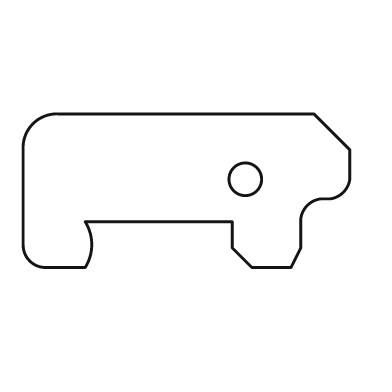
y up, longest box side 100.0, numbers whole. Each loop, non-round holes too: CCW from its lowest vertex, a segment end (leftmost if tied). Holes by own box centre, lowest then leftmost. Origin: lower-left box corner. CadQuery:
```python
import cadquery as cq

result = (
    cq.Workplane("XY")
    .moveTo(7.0, 0.0)
    .lineTo(19.0, 0.0)
    .threePointArc((21.0, 7.0), (19.0, 14.0))
    .lineTo(64.0, 14.0)
    .lineTo(64.0, 6.0)
    .lineTo(70.0, 0.0)
    .lineTo(82.0, 0.0)
    .lineTo(85.0, 6.0)
    .lineTo(85.0, 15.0)
    .threePointArc((87.0, 19.0), (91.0, 21.0))
    .lineTo(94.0, 21.0)
    .threePointArc((98.0, 23.0), (100.0, 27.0))
    .lineTo(100.0, 36.0)
    .lineTo(89.0, 47.0)
    .lineTo(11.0, 47.0)
    .threePointArc((3.0, 44.0), (0.0, 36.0))
    .lineTo(0.0, 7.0)
    .threePointArc((2.0, 2.0), (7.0, 0.0))
    .close()
    .moveTo(68.0, 27.0)
    .circle(5.0)
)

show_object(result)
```